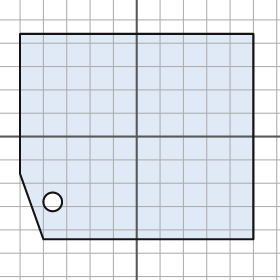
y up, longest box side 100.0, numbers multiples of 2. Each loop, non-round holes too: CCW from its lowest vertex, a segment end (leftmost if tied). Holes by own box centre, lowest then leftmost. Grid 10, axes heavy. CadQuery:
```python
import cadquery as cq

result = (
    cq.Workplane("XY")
    .moveTo(-40.0, -44.0)
    .lineTo(50.0, -44.0)
    .lineTo(50.0, 44.0)
    .lineTo(-50.0, 44.0)
    .lineTo(-50.0, -16.0)
    .close()
    .moveTo(-36.0, -28.0)
    .circle(4.0)
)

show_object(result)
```